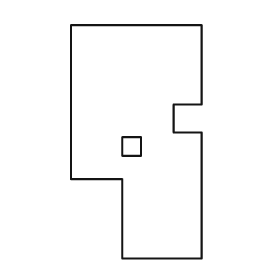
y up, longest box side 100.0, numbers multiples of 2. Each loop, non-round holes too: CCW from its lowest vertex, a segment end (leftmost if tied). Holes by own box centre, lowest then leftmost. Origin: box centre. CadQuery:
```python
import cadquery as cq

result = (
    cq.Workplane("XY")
    .moveTo(-6.0, -50.0)
    .lineTo(28.0, -50.0)
    .lineTo(28.0, 4.0)
    .lineTo(16.0, 4.0)
    .lineTo(16.0, 16.0)
    .lineTo(28.0, 16.0)
    .lineTo(28.0, 50.0)
    .lineTo(-28.0, 50.0)
    .lineTo(-28.0, -16.0)
    .lineTo(-6.0, -16.0)
    .close()
    .moveTo(-6.0, -6.0)
    .lineTo(2.0, -6.0)
    .lineTo(2.0, 2.0)
    .lineTo(-6.0, 2.0)
    .close()
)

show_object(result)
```